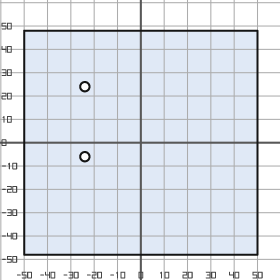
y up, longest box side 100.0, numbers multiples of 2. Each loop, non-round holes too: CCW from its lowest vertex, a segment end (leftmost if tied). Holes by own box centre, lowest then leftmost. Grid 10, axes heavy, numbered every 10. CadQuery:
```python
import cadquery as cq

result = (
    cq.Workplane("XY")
    .moveTo(-50.0, -48.0)
    .lineTo(50.0, -48.0)
    .lineTo(50.0, 48.0)
    .lineTo(-50.0, 48.0)
    .close()
    .moveTo(-24.0, -6.0)
    .circle(2.0)
    .moveTo(-24.0, 24.0)
    .circle(2.0)
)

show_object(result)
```